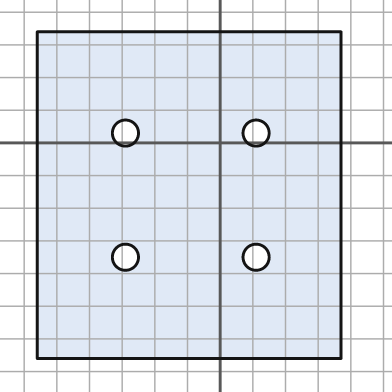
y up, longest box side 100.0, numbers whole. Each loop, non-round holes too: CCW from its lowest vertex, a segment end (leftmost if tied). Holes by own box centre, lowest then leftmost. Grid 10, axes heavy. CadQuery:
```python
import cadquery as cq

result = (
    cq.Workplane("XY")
    .moveTo(-56.0, -66.0)
    .lineTo(37.0, -66.0)
    .lineTo(37.0, 34.0)
    .lineTo(-56.0, 34.0)
    .close()
    .moveTo(-29.0, -35.0)
    .circle(4.0)
    .moveTo(11.0, -35.0)
    .circle(4.0)
    .moveTo(-29.0, 3.0)
    .circle(4.0)
    .moveTo(11.0, 3.0)
    .circle(4.0)
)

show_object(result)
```